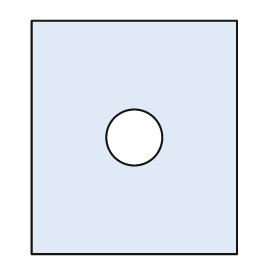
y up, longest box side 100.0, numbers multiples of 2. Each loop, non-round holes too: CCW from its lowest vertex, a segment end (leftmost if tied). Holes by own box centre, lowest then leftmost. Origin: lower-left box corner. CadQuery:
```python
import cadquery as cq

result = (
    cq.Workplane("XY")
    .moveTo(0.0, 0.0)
    .lineTo(88.0, 0.0)
    .lineTo(88.0, 100.0)
    .lineTo(0.0, 100.0)
    .close()
    .moveTo(44.0, 50.0)
    .circle(12.0)
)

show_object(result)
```